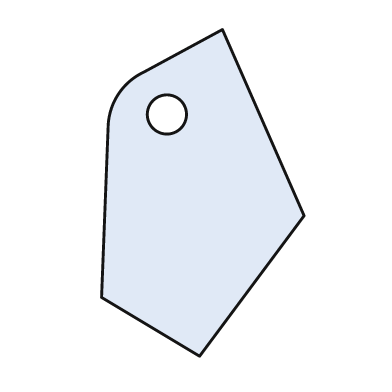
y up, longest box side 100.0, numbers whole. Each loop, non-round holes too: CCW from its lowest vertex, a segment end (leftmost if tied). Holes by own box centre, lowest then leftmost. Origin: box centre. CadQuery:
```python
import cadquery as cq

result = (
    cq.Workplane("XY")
    .moveTo(-1.0, -50.0)
    .lineTo(31.0, -7.0)
    .lineTo(6.0, 50.0)
    .lineTo(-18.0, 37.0)
    .threePointArc((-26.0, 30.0), (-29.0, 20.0))
    .lineTo(-31.0, -32.0)
    .close()
    .moveTo(-11.0, 24.0)
    .circle(6.0)
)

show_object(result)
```